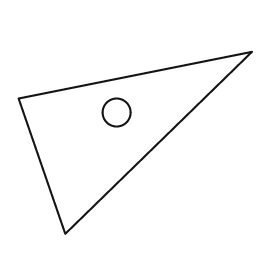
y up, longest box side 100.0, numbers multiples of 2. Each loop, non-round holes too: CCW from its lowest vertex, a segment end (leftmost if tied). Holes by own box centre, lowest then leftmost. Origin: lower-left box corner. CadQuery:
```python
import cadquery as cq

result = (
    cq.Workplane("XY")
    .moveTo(20.0, 0.0)
    .lineTo(100.0, 78.0)
    .lineTo(0.0, 58.0)
    .close()
    .moveTo(42.0, 52.0)
    .circle(6.0)
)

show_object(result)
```